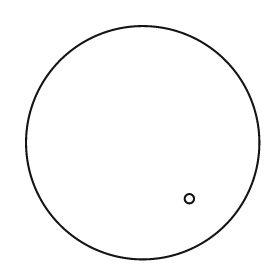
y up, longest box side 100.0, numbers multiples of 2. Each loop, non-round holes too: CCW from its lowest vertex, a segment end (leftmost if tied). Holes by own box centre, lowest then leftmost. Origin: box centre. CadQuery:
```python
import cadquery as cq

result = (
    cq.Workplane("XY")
    .moveTo(0.0, 0.0)
    .circle(50.0)
    .moveTo(20.0, -24.0)
    .circle(2.0)
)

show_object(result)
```